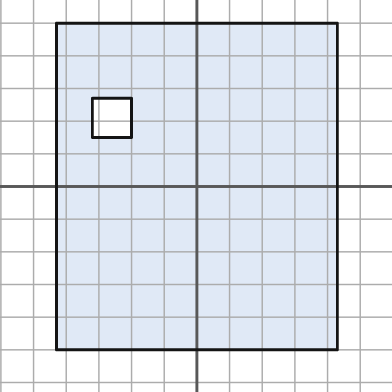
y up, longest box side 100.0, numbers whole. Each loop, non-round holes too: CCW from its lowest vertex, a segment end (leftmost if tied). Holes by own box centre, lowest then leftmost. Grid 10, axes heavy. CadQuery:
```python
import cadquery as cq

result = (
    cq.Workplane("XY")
    .moveTo(-43.0, -50.0)
    .lineTo(43.0, -50.0)
    .lineTo(43.0, 50.0)
    .lineTo(-43.0, 50.0)
    .close()
    .moveTo(-32.0, 15.0)
    .lineTo(-20.0, 15.0)
    .lineTo(-20.0, 27.0)
    .lineTo(-32.0, 27.0)
    .close()
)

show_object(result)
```